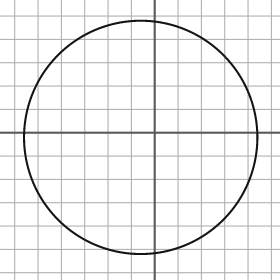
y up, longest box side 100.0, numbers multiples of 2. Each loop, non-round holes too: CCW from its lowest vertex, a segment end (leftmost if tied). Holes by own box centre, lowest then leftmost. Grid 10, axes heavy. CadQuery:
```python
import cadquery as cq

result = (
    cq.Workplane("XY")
    .moveTo(-6.0, -2.0)
    .circle(50.0)
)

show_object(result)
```